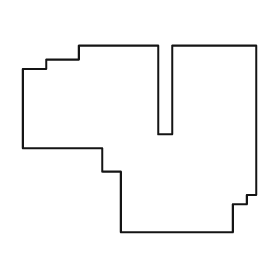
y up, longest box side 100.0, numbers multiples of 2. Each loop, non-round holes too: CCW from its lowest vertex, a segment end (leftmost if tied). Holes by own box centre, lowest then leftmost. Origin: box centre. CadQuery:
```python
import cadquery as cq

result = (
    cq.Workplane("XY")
    .moveTo(-8.0, -40.0)
    .lineTo(40.0, -40.0)
    .lineTo(40.0, -28.0)
    .lineTo(46.0, -28.0)
    .lineTo(46.0, -24.0)
    .lineTo(50.0, -24.0)
    .lineTo(50.0, 40.0)
    .lineTo(14.0, 40.0)
    .lineTo(14.0, 2.0)
    .lineTo(8.0, 2.0)
    .lineTo(8.0, 40.0)
    .lineTo(-26.0, 40.0)
    .lineTo(-26.0, 34.0)
    .lineTo(-40.0, 34.0)
    .lineTo(-40.0, 30.0)
    .lineTo(-50.0, 30.0)
    .lineTo(-50.0, -4.0)
    .lineTo(-16.0, -4.0)
    .lineTo(-16.0, -14.0)
    .lineTo(-8.0, -14.0)
    .close()
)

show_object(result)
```